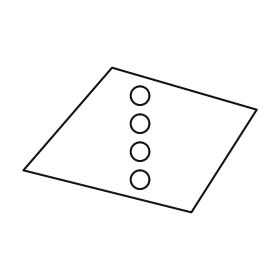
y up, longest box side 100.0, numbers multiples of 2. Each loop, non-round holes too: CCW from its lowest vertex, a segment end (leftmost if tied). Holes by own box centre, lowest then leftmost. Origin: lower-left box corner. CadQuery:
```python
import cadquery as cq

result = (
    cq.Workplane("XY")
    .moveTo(72.0, 0.0)
    .lineTo(100.0, 44.0)
    .lineTo(38.0, 62.0)
    .lineTo(0.0, 18.0)
    .close()
    .moveTo(50.0, 14.0)
    .circle(4.0)
    .moveTo(50.0, 26.0)
    .circle(4.0)
    .moveTo(50.0, 38.0)
    .circle(4.0)
    .moveTo(50.0, 50.0)
    .circle(4.0)
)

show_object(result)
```